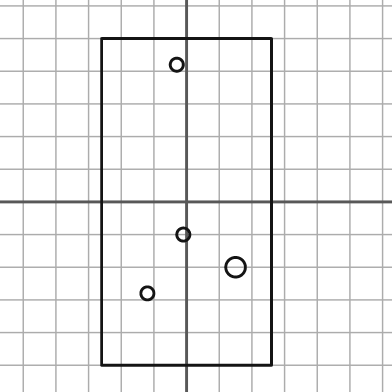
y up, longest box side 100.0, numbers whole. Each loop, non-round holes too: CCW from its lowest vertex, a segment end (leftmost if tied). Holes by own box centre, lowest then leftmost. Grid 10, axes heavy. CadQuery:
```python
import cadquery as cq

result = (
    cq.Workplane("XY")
    .moveTo(-26.0, -50.0)
    .lineTo(26.0, -50.0)
    .lineTo(26.0, 50.0)
    .lineTo(-26.0, 50.0)
    .close()
    .moveTo(-12.0, -28.0)
    .circle(2.0)
    .moveTo(15.0, -20.0)
    .circle(3.0)
    .moveTo(-1.0, -10.0)
    .circle(2.0)
    .moveTo(-3.0, 42.0)
    .circle(2.0)
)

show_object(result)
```